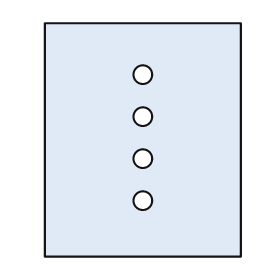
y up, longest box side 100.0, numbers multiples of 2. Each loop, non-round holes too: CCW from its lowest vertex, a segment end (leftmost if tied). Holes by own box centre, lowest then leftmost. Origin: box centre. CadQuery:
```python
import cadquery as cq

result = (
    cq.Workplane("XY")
    .moveTo(-42.0, -50.0)
    .lineTo(42.0, -50.0)
    .lineTo(42.0, 50.0)
    .lineTo(-42.0, 50.0)
    .close()
    .moveTo(0.0, -26.0)
    .circle(4.0)
    .moveTo(0.0, -8.0)
    .circle(4.0)
    .moveTo(0.0, 10.0)
    .circle(4.0)
    .moveTo(0.0, 28.0)
    .circle(4.0)
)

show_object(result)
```